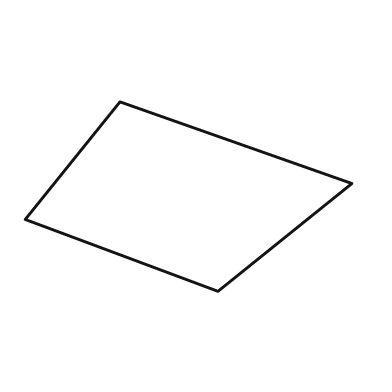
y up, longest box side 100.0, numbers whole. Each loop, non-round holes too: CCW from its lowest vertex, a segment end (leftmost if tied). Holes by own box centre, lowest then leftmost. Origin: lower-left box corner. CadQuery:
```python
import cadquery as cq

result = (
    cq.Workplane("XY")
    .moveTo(59.0, 0.0)
    .lineTo(100.0, 33.0)
    .lineTo(29.0, 58.0)
    .lineTo(0.0, 22.0)
    .close()
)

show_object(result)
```